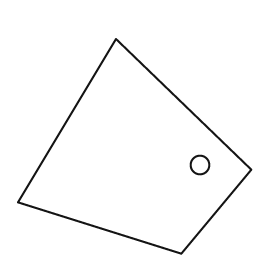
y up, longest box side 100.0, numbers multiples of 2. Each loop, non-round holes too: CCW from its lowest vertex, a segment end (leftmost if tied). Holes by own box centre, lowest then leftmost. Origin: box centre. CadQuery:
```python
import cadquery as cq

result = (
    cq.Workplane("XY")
    .moveTo(20.0, -46.0)
    .lineTo(50.0, -10.0)
    .lineTo(-8.0, 46.0)
    .lineTo(-50.0, -24.0)
    .close()
    .moveTo(28.0, -8.0)
    .circle(4.0)
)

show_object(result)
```